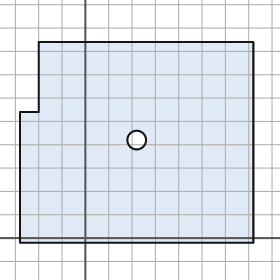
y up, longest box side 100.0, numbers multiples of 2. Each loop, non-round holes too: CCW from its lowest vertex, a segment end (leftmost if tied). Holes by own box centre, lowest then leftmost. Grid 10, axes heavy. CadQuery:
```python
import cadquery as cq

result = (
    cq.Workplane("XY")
    .moveTo(-28.0, -2.0)
    .lineTo(72.0, -2.0)
    .lineTo(72.0, 84.0)
    .lineTo(-20.0, 84.0)
    .lineTo(-20.0, 54.0)
    .lineTo(-28.0, 54.0)
    .close()
    .moveTo(22.0, 42.0)
    .circle(4.0)
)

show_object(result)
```